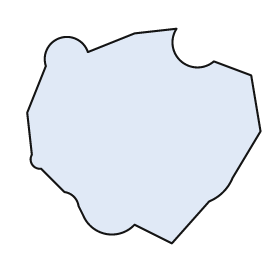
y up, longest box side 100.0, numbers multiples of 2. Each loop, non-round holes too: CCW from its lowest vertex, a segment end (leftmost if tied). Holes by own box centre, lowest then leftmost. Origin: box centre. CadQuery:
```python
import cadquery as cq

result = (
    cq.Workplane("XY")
    .moveTo(12.0, -46.0)
    .lineTo(28.0, -28.0)
    .threePointArc((34.0, -24.0), (38.0, -18.0))
    .lineTo(50.0, 2.0)
    .lineTo(46.0, 26.0)
    .lineTo(30.0, 32.0)
    .threePointArc((16.0, 32.0), (14.0, 46.0))
    .lineTo(-4.0, 44.0)
    .lineTo(-24.0, 36.0)
    .threePointArc((-36.0, 42.0), (-42.0, 30.0))
    .lineTo(-50.0, 10.0)
    .lineTo(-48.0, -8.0)
    .threePointArc((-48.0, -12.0), (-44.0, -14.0))
    .lineTo(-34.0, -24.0)
    .threePointArc((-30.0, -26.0), (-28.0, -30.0))
    .lineTo(-26.0, -34.0)
    .threePointArc((-16.0, -42.0), (-4.0, -38.0))
    .close()
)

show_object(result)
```